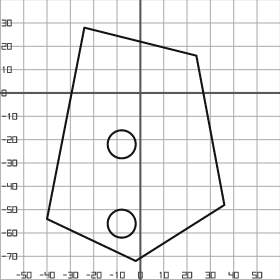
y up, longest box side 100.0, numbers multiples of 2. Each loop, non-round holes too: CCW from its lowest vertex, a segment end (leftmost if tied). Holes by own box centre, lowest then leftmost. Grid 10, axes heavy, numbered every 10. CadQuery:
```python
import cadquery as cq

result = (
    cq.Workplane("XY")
    .moveTo(-2.0, -72.0)
    .lineTo(36.0, -48.0)
    .lineTo(24.0, 16.0)
    .lineTo(-24.0, 28.0)
    .lineTo(-40.0, -54.0)
    .close()
    .moveTo(-8.0, -56.0)
    .circle(6.0)
    .moveTo(-8.0, -22.0)
    .circle(6.0)
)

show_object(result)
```